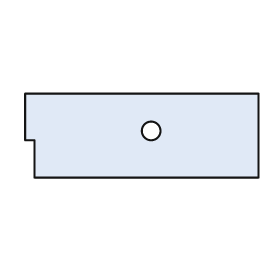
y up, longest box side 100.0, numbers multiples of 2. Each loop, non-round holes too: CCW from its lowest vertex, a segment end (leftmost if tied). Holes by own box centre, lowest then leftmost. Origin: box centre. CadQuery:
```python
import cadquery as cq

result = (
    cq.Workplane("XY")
    .moveTo(-46.0, -18.0)
    .lineTo(50.0, -18.0)
    .lineTo(50.0, 18.0)
    .lineTo(-50.0, 18.0)
    .lineTo(-50.0, -2.0)
    .lineTo(-46.0, -2.0)
    .close()
    .moveTo(4.0, 2.0)
    .circle(4.0)
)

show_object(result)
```